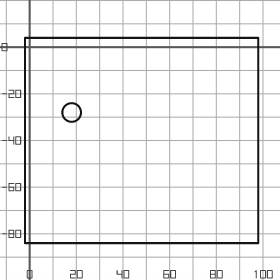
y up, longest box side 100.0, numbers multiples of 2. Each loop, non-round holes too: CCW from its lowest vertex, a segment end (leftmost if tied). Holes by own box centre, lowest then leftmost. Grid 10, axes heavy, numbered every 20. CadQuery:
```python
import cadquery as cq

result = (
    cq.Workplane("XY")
    .moveTo(-2.0, -84.0)
    .lineTo(98.0, -84.0)
    .lineTo(98.0, 4.0)
    .lineTo(-2.0, 4.0)
    .close()
    .moveTo(18.0, -28.0)
    .circle(4.0)
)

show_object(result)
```